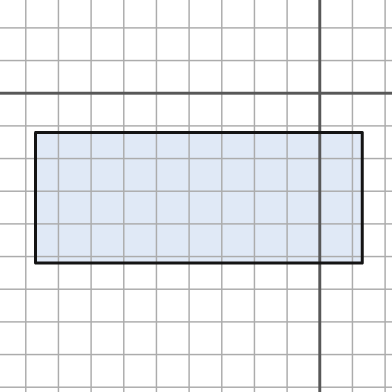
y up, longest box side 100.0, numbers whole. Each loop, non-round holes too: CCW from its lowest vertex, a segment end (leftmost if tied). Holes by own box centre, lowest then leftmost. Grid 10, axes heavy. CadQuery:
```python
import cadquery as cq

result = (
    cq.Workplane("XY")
    .moveTo(-87.0, -52.0)
    .lineTo(13.0, -52.0)
    .lineTo(13.0, -12.0)
    .lineTo(-87.0, -12.0)
    .close()
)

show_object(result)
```